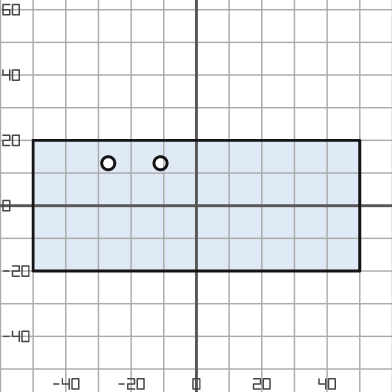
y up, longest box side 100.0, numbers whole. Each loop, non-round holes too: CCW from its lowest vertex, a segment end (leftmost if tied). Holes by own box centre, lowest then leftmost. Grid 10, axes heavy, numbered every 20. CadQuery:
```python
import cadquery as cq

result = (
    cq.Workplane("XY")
    .moveTo(-50.0, -20.0)
    .lineTo(50.0, -20.0)
    .lineTo(50.0, 20.0)
    .lineTo(-50.0, 20.0)
    .close()
    .moveTo(-27.0, 13.0)
    .circle(2.0)
    .moveTo(-11.0, 13.0)
    .circle(2.0)
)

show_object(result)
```